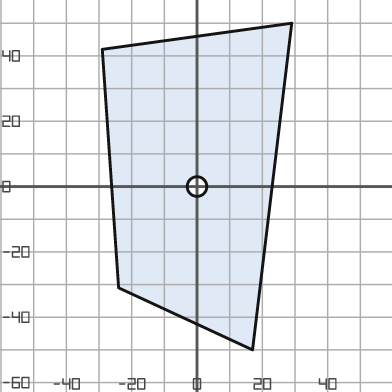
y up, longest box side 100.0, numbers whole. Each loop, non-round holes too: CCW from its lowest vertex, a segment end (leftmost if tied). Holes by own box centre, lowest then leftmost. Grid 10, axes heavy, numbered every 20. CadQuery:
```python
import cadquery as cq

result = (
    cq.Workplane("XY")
    .moveTo(17.0, -50.0)
    .lineTo(29.0, 50.0)
    .lineTo(-29.0, 42.0)
    .lineTo(-24.0, -31.0)
    .close()
    .moveTo(0.0, 0.0)
    .circle(3.0)
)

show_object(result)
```